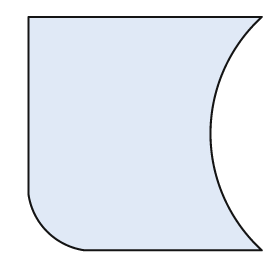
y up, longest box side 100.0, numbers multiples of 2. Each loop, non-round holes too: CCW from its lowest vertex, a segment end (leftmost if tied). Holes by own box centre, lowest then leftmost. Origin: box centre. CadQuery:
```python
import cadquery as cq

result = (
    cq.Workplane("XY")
    .moveTo(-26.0, -50.0)
    .lineTo(50.0, -50.0)
    .threePointArc((28.0, 0.0), (50.0, 50.0))
    .lineTo(-50.0, 50.0)
    .lineTo(-50.0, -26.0)
    .threePointArc((-42.0, -42.0), (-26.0, -50.0))
    .close()
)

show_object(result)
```